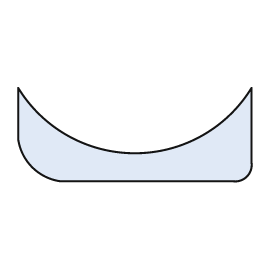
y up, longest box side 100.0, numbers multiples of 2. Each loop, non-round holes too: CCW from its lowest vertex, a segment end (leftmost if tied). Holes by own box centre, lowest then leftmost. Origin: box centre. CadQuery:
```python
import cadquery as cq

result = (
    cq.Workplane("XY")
    .moveTo(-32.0, -20.0)
    .lineTo(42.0, -20.0)
    .threePointArc((48.0, -18.0), (50.0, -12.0))
    .lineTo(50.0, 20.0)
    .threePointArc((0.0, -8.0), (-50.0, 20.0))
    .lineTo(-50.0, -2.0)
    .threePointArc((-44.0, -14.0), (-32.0, -20.0))
    .close()
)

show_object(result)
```